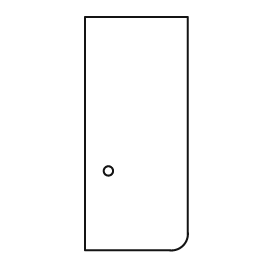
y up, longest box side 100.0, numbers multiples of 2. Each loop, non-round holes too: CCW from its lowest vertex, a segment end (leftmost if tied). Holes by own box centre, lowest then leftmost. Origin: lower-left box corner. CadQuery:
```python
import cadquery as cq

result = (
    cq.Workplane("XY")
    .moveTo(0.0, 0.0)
    .lineTo(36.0, 0.0)
    .threePointArc((42.0, 2.0), (44.0, 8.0))
    .lineTo(44.0, 100.0)
    .lineTo(0.0, 100.0)
    .close()
    .moveTo(10.0, 34.0)
    .circle(2.0)
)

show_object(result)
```